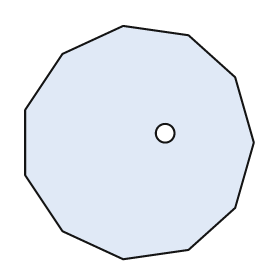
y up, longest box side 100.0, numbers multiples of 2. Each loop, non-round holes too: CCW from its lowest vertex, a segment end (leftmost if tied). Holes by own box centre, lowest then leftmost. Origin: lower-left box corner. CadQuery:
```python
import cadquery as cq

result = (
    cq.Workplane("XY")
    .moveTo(42.0, 0.0)
    .lineTo(70.0, 4.0)
    .lineTo(90.0, 22.0)
    .lineTo(98.0, 50.0)
    .lineTo(90.0, 78.0)
    .lineTo(70.0, 96.0)
    .lineTo(42.0, 100.0)
    .lineTo(16.0, 88.0)
    .lineTo(0.0, 64.0)
    .lineTo(0.0, 36.0)
    .lineTo(16.0, 12.0)
    .close()
    .moveTo(60.0, 54.0)
    .circle(4.0)
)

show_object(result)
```